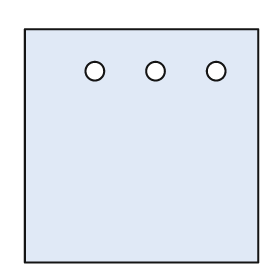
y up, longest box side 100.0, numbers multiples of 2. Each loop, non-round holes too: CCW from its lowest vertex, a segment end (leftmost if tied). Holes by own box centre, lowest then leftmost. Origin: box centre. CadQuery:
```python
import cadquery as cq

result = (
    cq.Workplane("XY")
    .moveTo(-50.0, -50.0)
    .lineTo(50.0, -50.0)
    .lineTo(50.0, 50.0)
    .lineTo(-50.0, 50.0)
    .close()
    .moveTo(-20.0, 32.0)
    .circle(4.0)
    .moveTo(6.0, 32.0)
    .circle(4.0)
    .moveTo(32.0, 32.0)
    .circle(4.0)
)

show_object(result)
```